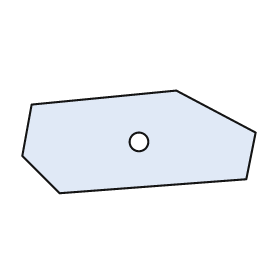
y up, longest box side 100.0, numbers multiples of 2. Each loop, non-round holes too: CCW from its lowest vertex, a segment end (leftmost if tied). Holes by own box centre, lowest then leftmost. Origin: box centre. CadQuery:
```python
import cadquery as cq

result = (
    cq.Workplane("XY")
    .moveTo(-34.0, -22.0)
    .lineTo(46.0, -16.0)
    .lineTo(50.0, 4.0)
    .lineTo(16.0, 22.0)
    .lineTo(-46.0, 16.0)
    .lineTo(-50.0, -6.0)
    .close()
    .moveTo(0.0, 0.0)
    .circle(4.0)
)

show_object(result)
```